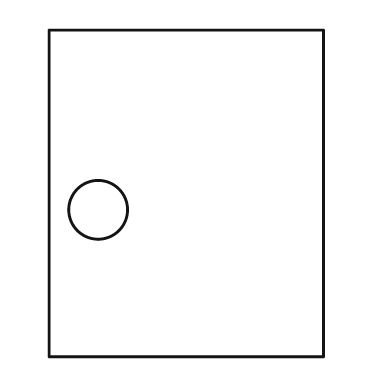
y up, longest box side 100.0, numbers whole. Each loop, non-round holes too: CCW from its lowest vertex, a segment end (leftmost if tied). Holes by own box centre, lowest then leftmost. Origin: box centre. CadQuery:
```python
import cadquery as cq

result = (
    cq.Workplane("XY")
    .moveTo(-42.0, -50.0)
    .lineTo(42.0, -50.0)
    .lineTo(42.0, 50.0)
    .lineTo(-42.0, 50.0)
    .close()
    .moveTo(-27.0, -5.0)
    .circle(9.0)
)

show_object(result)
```